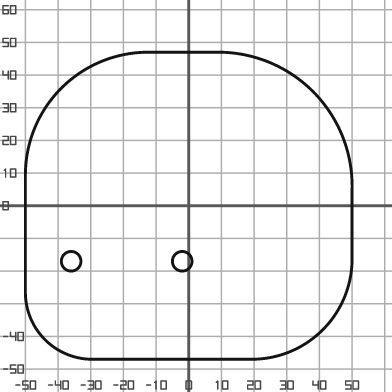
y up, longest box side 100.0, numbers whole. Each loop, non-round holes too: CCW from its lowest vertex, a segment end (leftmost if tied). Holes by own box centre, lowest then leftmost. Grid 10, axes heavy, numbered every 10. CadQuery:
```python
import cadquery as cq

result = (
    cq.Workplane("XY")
    .moveTo(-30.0, -47.0)
    .lineTo(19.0, -47.0)
    .threePointArc((41.0, -38.0), (50.0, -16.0))
    .lineTo(50.0, 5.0)
    .threePointArc((38.0, 35.0), (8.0, 47.0))
    .lineTo(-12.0, 47.0)
    .threePointArc((-39.0, 36.0), (-50.0, 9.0))
    .lineTo(-50.0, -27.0)
    .threePointArc((-44.0, -41.0), (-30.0, -47.0))
    .close()
    .moveTo(-36.0, -17.0)
    .circle(3.0)
    .moveTo(-2.0, -17.0)
    .circle(3.0)
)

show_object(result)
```